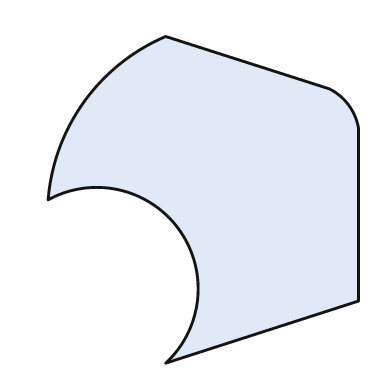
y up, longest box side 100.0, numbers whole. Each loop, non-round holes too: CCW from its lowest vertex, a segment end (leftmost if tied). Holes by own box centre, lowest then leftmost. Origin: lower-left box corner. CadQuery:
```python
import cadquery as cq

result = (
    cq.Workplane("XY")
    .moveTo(36.0, 0.0)
    .lineTo(95.0, 19.0)
    .lineTo(95.0, 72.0)
    .threePointArc((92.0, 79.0), (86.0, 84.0))
    .lineTo(36.0, 100.0)
    .threePointArc((11.0, 80.0), (0.0, 50.0))
    .threePointArc((40.0, 41.0), (36.0, 0.0))
    .close()
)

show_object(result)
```